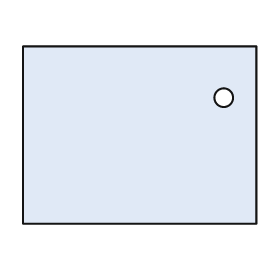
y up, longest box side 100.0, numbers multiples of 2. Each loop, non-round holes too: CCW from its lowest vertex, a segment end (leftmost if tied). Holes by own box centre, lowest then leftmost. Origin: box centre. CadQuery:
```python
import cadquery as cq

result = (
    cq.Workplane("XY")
    .moveTo(-50.0, -38.0)
    .lineTo(50.0, -38.0)
    .lineTo(50.0, 38.0)
    .lineTo(-50.0, 38.0)
    .close()
    .moveTo(36.0, 16.0)
    .circle(4.0)
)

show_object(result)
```